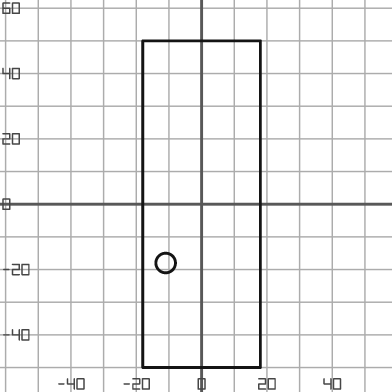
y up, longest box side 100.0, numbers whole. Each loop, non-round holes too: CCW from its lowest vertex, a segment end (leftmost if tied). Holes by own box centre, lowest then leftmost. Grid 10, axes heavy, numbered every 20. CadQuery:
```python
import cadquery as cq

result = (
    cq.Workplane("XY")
    .moveTo(-18.0, -50.0)
    .lineTo(18.0, -50.0)
    .lineTo(18.0, 50.0)
    .lineTo(-18.0, 50.0)
    .close()
    .moveTo(-11.0, -18.0)
    .circle(3.0)
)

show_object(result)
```